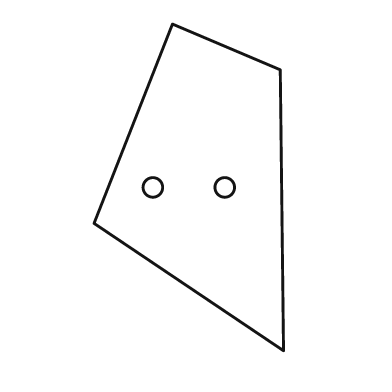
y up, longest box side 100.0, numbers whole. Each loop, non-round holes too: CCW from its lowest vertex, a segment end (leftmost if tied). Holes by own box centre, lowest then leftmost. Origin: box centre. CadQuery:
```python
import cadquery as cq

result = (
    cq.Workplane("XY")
    .moveTo(29.0, -50.0)
    .lineTo(28.0, 36.0)
    .lineTo(-5.0, 50.0)
    .lineTo(-29.0, -11.0)
    .close()
    .moveTo(-11.0, 0.0)
    .circle(3.0)
    .moveTo(11.0, 0.0)
    .circle(3.0)
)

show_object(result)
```